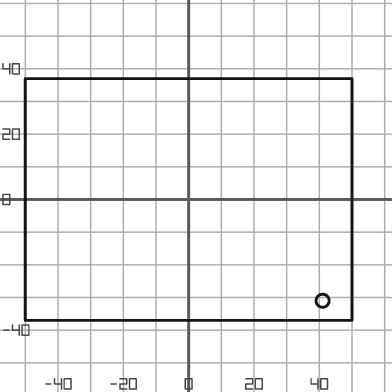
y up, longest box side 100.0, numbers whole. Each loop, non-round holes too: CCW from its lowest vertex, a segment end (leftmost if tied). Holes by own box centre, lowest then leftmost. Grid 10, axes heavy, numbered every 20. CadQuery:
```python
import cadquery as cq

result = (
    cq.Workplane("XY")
    .moveTo(-50.0, -37.0)
    .lineTo(50.0, -37.0)
    .lineTo(50.0, 37.0)
    .lineTo(-50.0, 37.0)
    .close()
    .moveTo(41.0, -31.0)
    .circle(2.0)
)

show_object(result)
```